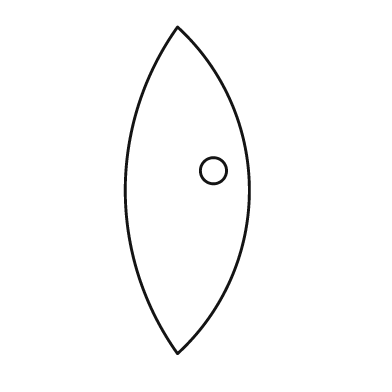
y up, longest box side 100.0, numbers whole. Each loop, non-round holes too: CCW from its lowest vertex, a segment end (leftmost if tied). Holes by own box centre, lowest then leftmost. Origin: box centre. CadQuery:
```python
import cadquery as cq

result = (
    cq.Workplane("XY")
    .moveTo(-3.0, -50.0)
    .threePointArc((19.0, 0.0), (-3.0, 50.0))
    .threePointArc((-19.0, 0.0), (-3.0, -50.0))
    .close()
    .moveTo(8.0, 6.0)
    .circle(4.0)
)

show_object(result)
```